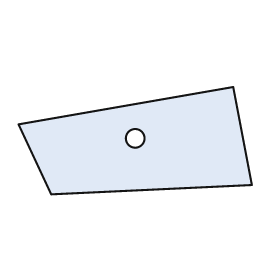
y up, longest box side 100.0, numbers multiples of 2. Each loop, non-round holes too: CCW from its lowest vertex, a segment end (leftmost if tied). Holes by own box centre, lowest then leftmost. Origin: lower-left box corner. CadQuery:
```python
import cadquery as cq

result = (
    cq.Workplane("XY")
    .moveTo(14.0, 0.0)
    .lineTo(100.0, 4.0)
    .lineTo(92.0, 46.0)
    .lineTo(0.0, 30.0)
    .close()
    .moveTo(50.0, 24.0)
    .circle(4.0)
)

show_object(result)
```